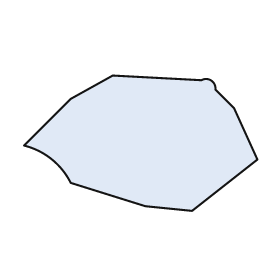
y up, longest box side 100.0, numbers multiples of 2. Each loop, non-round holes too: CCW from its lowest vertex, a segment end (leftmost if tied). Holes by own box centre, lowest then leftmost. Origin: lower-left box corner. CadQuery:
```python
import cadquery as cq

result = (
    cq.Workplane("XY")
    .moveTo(72.0, 0.0)
    .lineTo(100.0, 22.0)
    .lineTo(90.0, 44.0)
    .lineTo(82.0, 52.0)
    .threePointArc((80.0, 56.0), (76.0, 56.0))
    .lineTo(38.0, 58.0)
    .lineTo(20.0, 48.0)
    .lineTo(0.0, 28.0)
    .threePointArc((12.0, 22.0), (20.0, 12.0))
    .lineTo(52.0, 2.0)
    .close()
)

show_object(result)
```